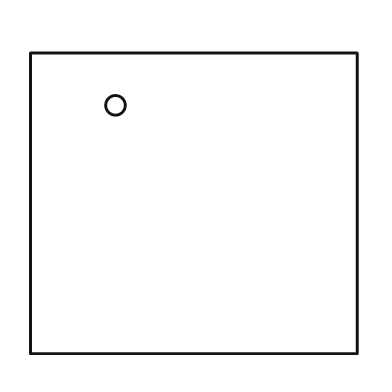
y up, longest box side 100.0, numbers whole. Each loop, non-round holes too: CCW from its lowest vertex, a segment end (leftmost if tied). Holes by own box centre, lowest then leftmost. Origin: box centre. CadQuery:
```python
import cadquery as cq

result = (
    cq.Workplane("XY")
    .moveTo(-50.0, -46.0)
    .lineTo(50.0, -46.0)
    .lineTo(50.0, 46.0)
    .lineTo(-50.0, 46.0)
    .close()
    .moveTo(-24.0, 30.0)
    .circle(3.0)
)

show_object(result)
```